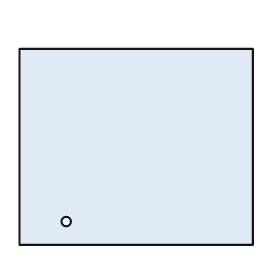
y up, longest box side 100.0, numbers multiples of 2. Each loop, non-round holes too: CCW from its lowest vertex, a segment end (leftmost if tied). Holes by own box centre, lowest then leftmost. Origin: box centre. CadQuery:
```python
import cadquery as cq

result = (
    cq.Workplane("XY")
    .moveTo(-50.0, -42.0)
    .lineTo(50.0, -42.0)
    .lineTo(50.0, 42.0)
    .lineTo(-50.0, 42.0)
    .close()
    .moveTo(-30.0, -32.0)
    .circle(2.0)
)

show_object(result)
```